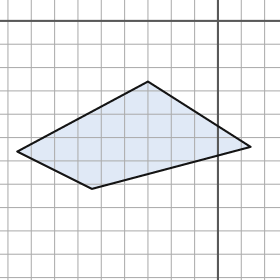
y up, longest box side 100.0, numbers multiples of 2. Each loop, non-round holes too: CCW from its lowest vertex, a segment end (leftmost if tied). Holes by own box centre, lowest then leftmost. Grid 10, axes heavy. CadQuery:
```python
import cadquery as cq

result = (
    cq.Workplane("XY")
    .moveTo(-54.0, -72.0)
    .lineTo(14.0, -54.0)
    .lineTo(-30.0, -26.0)
    .lineTo(-86.0, -56.0)
    .close()
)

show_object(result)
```